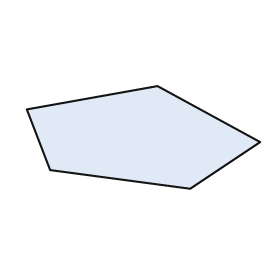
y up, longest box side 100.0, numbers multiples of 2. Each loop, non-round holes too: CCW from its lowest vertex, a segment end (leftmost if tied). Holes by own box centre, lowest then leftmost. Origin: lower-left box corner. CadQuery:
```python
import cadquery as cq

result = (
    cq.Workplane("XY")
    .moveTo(70.0, 0.0)
    .lineTo(100.0, 20.0)
    .lineTo(56.0, 44.0)
    .lineTo(0.0, 34.0)
    .lineTo(10.0, 8.0)
    .close()
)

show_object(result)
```